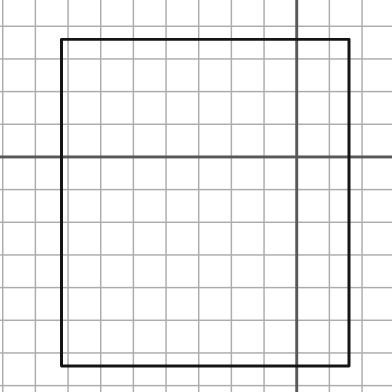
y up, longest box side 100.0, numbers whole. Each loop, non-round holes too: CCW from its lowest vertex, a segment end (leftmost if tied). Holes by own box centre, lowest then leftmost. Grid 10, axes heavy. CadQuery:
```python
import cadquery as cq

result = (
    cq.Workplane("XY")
    .moveTo(-72.0, -64.0)
    .lineTo(16.0, -64.0)
    .lineTo(16.0, 36.0)
    .lineTo(-72.0, 36.0)
    .close()
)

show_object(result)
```